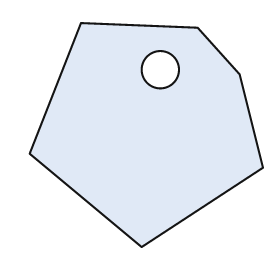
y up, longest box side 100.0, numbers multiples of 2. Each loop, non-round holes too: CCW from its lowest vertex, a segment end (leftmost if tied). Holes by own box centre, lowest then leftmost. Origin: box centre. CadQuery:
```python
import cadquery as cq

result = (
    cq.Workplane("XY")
    .moveTo(-2.0, -48.0)
    .lineTo(50.0, -14.0)
    .lineTo(40.0, 26.0)
    .lineTo(22.0, 46.0)
    .lineTo(-28.0, 48.0)
    .lineTo(-50.0, -8.0)
    .close()
    .moveTo(6.0, 28.0)
    .circle(8.0)
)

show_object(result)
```